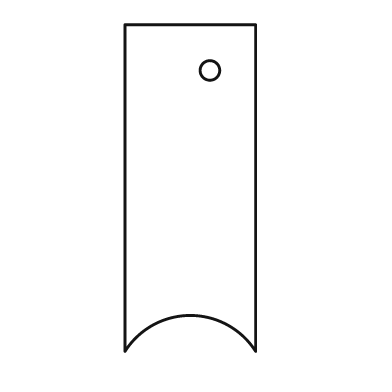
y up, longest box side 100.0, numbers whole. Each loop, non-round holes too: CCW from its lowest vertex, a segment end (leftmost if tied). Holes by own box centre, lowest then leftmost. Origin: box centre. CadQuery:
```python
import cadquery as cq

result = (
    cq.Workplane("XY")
    .moveTo(-20.0, -50.0)
    .threePointArc((0.0, -39.0), (20.0, -50.0))
    .lineTo(20.0, 50.0)
    .lineTo(-20.0, 50.0)
    .close()
    .moveTo(6.0, 36.0)
    .circle(3.0)
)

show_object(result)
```